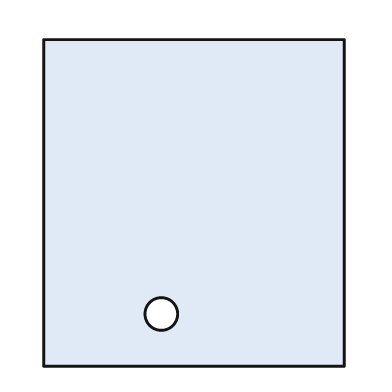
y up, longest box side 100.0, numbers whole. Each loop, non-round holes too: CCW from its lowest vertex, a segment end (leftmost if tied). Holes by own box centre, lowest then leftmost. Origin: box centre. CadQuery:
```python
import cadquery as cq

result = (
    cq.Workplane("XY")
    .moveTo(-46.0, -50.0)
    .lineTo(46.0, -50.0)
    .lineTo(46.0, 50.0)
    .lineTo(-46.0, 50.0)
    .close()
    .moveTo(-10.0, -34.0)
    .circle(5.0)
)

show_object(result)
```